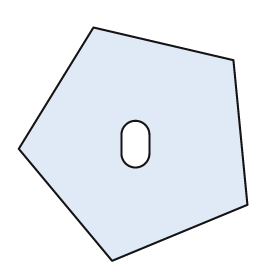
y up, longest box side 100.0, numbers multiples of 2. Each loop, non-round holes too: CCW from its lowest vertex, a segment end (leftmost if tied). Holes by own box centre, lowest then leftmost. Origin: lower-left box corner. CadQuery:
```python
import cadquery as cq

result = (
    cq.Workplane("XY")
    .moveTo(40.0, 0.0)
    .lineTo(98.0, 24.0)
    .lineTo(92.0, 86.0)
    .lineTo(32.0, 100.0)
    .lineTo(0.0, 48.0)
    .close()
    .moveTo(44.0, 46.0)
    .threePointArc((50.0, 40.0), (56.0, 46.0))
    .lineTo(56.0, 54.0)
    .threePointArc((50.0, 60.0), (44.0, 54.0))
    .close()
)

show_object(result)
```